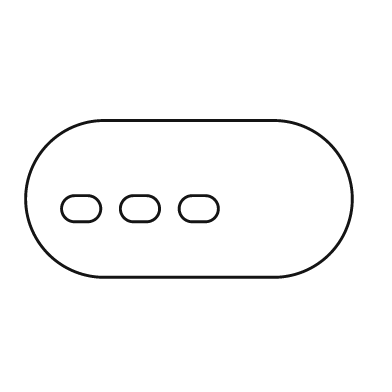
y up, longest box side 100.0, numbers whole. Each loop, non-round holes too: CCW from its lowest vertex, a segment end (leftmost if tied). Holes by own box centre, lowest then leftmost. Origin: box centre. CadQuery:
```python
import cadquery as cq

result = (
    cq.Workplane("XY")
    .moveTo(-26.0, -24.0)
    .lineTo(26.0, -24.0)
    .threePointArc((50.0, 0.0), (26.0, 24.0))
    .lineTo(-26.0, 24.0)
    .threePointArc((-50.0, 0.0), (-26.0, -24.0))
    .close()
    .moveTo(-35.0, -7.0)
    .lineTo(-31.0, -7.0)
    .threePointArc((-27.0, -3.0), (-31.0, 1.0))
    .lineTo(-35.0, 1.0)
    .threePointArc((-39.0, -3.0), (-35.0, -7.0))
    .close()
    .moveTo(-17.0, -7.0)
    .lineTo(-13.0, -7.0)
    .threePointArc((-9.0, -3.0), (-13.0, 1.0))
    .lineTo(-17.0, 1.0)
    .threePointArc((-21.0, -3.0), (-17.0, -7.0))
    .close()
    .moveTo(1.0, -7.0)
    .lineTo(5.0, -7.0)
    .threePointArc((9.0, -3.0), (5.0, 1.0))
    .lineTo(1.0, 1.0)
    .threePointArc((-3.0, -3.0), (1.0, -7.0))
    .close()
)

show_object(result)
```